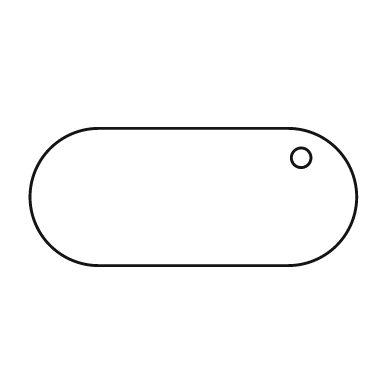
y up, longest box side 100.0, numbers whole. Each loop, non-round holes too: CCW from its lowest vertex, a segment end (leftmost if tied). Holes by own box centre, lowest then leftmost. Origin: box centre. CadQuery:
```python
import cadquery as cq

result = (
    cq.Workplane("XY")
    .moveTo(-29.0, -21.0)
    .lineTo(29.0, -21.0)
    .threePointArc((50.0, 0.0), (29.0, 21.0))
    .lineTo(-29.0, 21.0)
    .threePointArc((-50.0, 0.0), (-29.0, -21.0))
    .close()
    .moveTo(33.0, 12.0)
    .circle(3.0)
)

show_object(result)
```